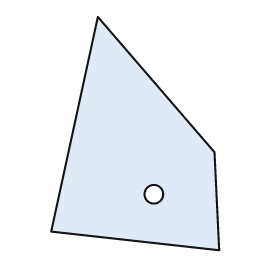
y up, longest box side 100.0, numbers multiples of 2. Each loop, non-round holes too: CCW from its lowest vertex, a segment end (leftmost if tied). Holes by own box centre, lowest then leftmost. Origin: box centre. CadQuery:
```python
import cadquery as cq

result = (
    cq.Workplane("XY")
    .moveTo(36.0, -50.0)
    .lineTo(34.0, -8.0)
    .lineTo(-16.0, 50.0)
    .lineTo(-36.0, -42.0)
    .close()
    .moveTo(8.0, -26.0)
    .circle(4.0)
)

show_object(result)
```